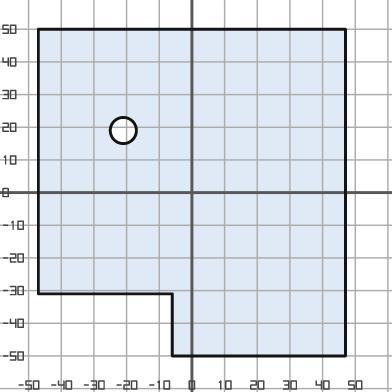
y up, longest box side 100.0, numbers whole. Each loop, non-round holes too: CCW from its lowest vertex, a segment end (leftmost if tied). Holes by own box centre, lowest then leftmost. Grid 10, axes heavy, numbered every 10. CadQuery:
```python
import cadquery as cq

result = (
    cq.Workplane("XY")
    .moveTo(-6.0, -50.0)
    .lineTo(47.0, -50.0)
    .lineTo(47.0, 50.0)
    .lineTo(-47.0, 50.0)
    .lineTo(-47.0, -31.0)
    .lineTo(-6.0, -31.0)
    .close()
    .moveTo(-21.0, 19.0)
    .circle(4.0)
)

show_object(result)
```